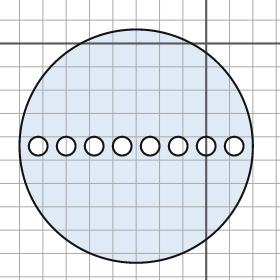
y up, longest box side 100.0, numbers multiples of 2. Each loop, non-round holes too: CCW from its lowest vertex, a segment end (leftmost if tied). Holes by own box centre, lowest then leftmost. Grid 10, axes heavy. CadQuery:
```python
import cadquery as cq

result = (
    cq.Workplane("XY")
    .moveTo(-30.0, -44.0)
    .circle(50.0)
    .moveTo(-72.0, -44.0)
    .circle(4.0)
    .moveTo(-60.0, -44.0)
    .circle(4.0)
    .moveTo(-48.0, -44.0)
    .circle(4.0)
    .moveTo(-36.0, -44.0)
    .circle(4.0)
    .moveTo(-24.0, -44.0)
    .circle(4.0)
    .moveTo(-12.0, -44.0)
    .circle(4.0)
    .moveTo(0.0, -44.0)
    .circle(4.0)
    .moveTo(12.0, -44.0)
    .circle(4.0)
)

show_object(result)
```